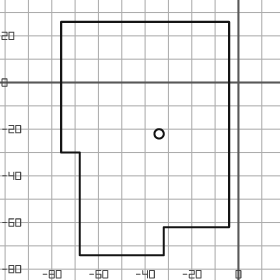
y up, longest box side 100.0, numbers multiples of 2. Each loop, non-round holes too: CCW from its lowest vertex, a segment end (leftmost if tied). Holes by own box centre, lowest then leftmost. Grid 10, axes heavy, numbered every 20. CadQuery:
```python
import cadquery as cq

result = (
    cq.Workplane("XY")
    .moveTo(-68.0, -74.0)
    .lineTo(-32.0, -74.0)
    .lineTo(-32.0, -62.0)
    .lineTo(-4.0, -62.0)
    .lineTo(-4.0, 26.0)
    .lineTo(-76.0, 26.0)
    .lineTo(-76.0, -30.0)
    .lineTo(-68.0, -30.0)
    .close()
    .moveTo(-34.0, -22.0)
    .circle(2.0)
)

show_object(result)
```